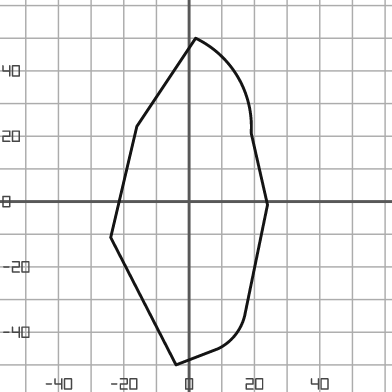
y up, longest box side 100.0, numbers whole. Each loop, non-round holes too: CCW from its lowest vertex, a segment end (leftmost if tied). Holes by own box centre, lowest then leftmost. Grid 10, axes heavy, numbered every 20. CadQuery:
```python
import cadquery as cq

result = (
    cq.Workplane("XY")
    .moveTo(-4.0, -50.0)
    .lineTo(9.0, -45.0)
    .threePointArc((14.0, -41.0), (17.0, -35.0))
    .lineTo(24.0, -1.0)
    .lineTo(19.0, 21.0)
    .threePointArc((15.0, 38.0), (2.0, 50.0))
    .lineTo(-16.0, 23.0)
    .lineTo(-24.0, -11.0)
    .close()
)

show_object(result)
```